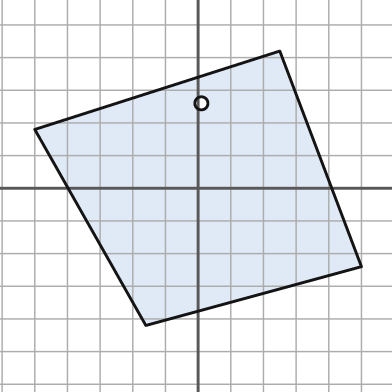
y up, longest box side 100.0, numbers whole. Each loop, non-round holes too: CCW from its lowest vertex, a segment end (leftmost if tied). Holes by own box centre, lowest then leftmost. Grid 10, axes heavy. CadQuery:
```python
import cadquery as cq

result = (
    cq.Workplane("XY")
    .moveTo(-16.0, -42.0)
    .lineTo(50.0, -24.0)
    .lineTo(25.0, 42.0)
    .lineTo(-50.0, 18.0)
    .close()
    .moveTo(1.0, 26.0)
    .circle(2.0)
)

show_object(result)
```